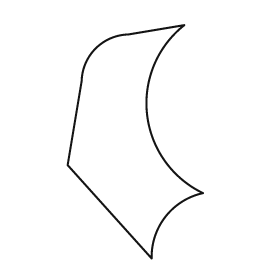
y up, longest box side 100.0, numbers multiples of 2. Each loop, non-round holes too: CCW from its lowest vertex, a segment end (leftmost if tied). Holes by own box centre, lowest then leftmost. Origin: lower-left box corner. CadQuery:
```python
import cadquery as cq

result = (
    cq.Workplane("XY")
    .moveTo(36.0, 0.0)
    .threePointArc((42.0, 18.0), (58.0, 28.0))
    .threePointArc((34.0, 62.0), (50.0, 100.0))
    .lineTo(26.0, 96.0)
    .threePointArc((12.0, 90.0), (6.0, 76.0))
    .lineTo(0.0, 40.0)
    .close()
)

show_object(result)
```